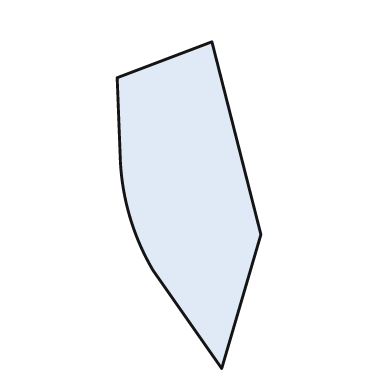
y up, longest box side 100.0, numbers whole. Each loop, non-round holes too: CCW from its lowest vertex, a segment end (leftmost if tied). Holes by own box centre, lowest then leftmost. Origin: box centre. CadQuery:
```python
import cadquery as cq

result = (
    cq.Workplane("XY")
    .moveTo(10.0, -50.0)
    .lineTo(22.0, -9.0)
    .lineTo(7.0, 50.0)
    .lineTo(-22.0, 39.0)
    .lineTo(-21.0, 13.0)
    .threePointArc((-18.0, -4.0), (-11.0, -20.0))
    .close()
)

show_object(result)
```